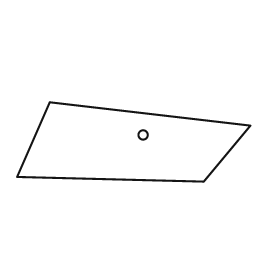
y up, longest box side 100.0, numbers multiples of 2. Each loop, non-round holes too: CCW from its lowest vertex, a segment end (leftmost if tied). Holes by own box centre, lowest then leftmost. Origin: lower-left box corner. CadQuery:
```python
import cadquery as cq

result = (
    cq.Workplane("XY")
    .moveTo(80.0, 0.0)
    .lineTo(100.0, 24.0)
    .lineTo(14.0, 34.0)
    .lineTo(0.0, 2.0)
    .close()
    .moveTo(54.0, 20.0)
    .circle(2.0)
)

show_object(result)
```